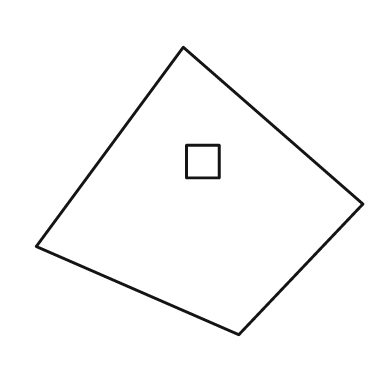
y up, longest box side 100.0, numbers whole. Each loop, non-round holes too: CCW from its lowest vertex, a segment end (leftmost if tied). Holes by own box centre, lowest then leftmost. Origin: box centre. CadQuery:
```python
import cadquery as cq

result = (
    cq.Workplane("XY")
    .moveTo(12.0, -44.0)
    .lineTo(50.0, -4.0)
    .lineTo(-5.0, 44.0)
    .lineTo(-50.0, -17.0)
    .close()
    .moveTo(-4.0, 4.0)
    .lineTo(6.0, 4.0)
    .lineTo(6.0, 14.0)
    .lineTo(-4.0, 14.0)
    .close()
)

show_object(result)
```